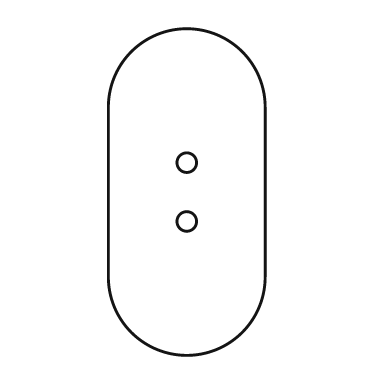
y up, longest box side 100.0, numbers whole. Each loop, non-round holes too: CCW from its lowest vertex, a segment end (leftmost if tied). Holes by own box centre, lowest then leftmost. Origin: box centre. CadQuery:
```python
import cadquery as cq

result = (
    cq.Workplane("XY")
    .moveTo(-24.0, -26.0)
    .threePointArc((0.0, -50.0), (24.0, -26.0))
    .lineTo(24.0, 26.0)
    .threePointArc((0.0, 50.0), (-24.0, 26.0))
    .close()
    .moveTo(0.0, -9.0)
    .circle(3.0)
    .moveTo(0.0, 9.0)
    .circle(3.0)
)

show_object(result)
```